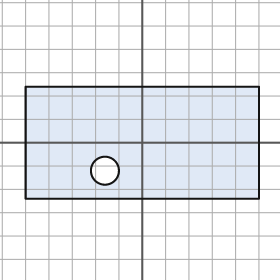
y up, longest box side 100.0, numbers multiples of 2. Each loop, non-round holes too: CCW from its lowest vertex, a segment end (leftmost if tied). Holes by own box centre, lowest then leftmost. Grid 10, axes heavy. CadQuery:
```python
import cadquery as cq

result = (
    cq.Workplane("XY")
    .moveTo(-50.0, -24.0)
    .lineTo(50.0, -24.0)
    .lineTo(50.0, 24.0)
    .lineTo(-50.0, 24.0)
    .close()
    .moveTo(-16.0, -12.0)
    .circle(6.0)
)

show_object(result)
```